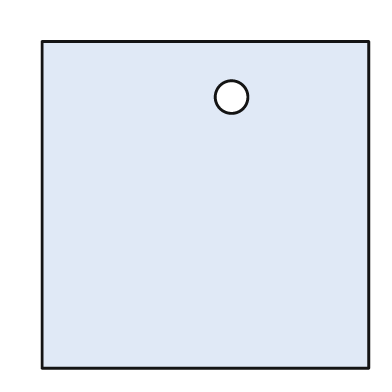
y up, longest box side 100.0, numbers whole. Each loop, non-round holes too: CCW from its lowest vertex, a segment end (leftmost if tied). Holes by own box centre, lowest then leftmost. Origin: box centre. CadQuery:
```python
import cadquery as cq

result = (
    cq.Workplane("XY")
    .moveTo(-50.0, -50.0)
    .lineTo(50.0, -50.0)
    .lineTo(50.0, 50.0)
    .lineTo(-50.0, 50.0)
    .close()
    .moveTo(8.0, 33.0)
    .circle(5.0)
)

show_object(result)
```